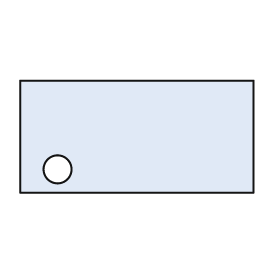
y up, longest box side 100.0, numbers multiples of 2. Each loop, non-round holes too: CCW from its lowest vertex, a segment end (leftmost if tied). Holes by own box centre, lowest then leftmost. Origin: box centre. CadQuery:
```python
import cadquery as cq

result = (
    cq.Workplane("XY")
    .moveTo(-50.0, -24.0)
    .lineTo(50.0, -24.0)
    .lineTo(50.0, 24.0)
    .lineTo(-50.0, 24.0)
    .close()
    .moveTo(-34.0, -14.0)
    .circle(6.0)
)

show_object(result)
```